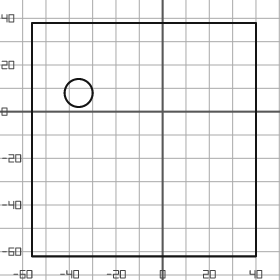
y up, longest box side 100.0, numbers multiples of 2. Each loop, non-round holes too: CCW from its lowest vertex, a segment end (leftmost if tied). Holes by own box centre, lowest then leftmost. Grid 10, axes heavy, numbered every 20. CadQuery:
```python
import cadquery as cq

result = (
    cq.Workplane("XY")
    .moveTo(-56.0, -62.0)
    .lineTo(40.0, -62.0)
    .lineTo(40.0, 38.0)
    .lineTo(-56.0, 38.0)
    .close()
    .moveTo(-36.0, 8.0)
    .circle(6.0)
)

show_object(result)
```